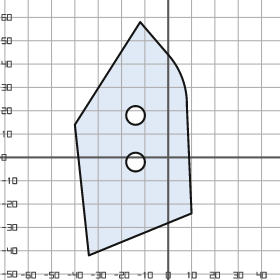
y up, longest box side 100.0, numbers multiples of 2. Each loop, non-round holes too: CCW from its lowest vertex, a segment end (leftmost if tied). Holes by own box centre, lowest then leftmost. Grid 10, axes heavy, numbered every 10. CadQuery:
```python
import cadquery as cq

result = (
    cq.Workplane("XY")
    .moveTo(-34.0, -42.0)
    .lineTo(10.0, -24.0)
    .lineTo(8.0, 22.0)
    .threePointArc((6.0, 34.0), (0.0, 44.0))
    .lineTo(-12.0, 58.0)
    .lineTo(-40.0, 14.0)
    .close()
    .moveTo(-14.0, -2.0)
    .circle(4.0)
    .moveTo(-14.0, 18.0)
    .circle(4.0)
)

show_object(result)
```